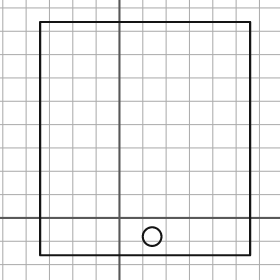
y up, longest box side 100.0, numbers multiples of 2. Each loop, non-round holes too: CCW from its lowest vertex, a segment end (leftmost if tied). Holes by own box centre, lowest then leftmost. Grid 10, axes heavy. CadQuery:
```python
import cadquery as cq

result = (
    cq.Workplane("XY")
    .moveTo(-34.0, -16.0)
    .lineTo(56.0, -16.0)
    .lineTo(56.0, 84.0)
    .lineTo(-34.0, 84.0)
    .close()
    .moveTo(14.0, -8.0)
    .circle(4.0)
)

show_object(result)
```